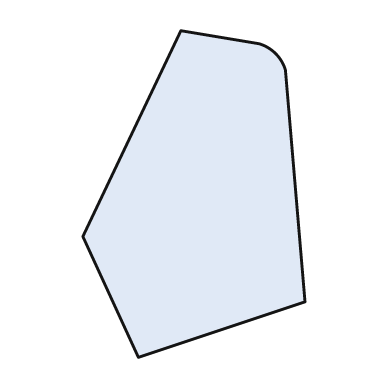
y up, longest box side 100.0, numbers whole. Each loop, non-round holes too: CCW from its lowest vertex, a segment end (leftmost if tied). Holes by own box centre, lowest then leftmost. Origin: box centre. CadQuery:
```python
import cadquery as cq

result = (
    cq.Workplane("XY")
    .moveTo(-17.0, -50.0)
    .lineTo(34.0, -33.0)
    .lineTo(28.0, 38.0)
    .threePointArc((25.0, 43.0), (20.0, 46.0))
    .lineTo(-4.0, 50.0)
    .lineTo(-34.0, -13.0)
    .close()
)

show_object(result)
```